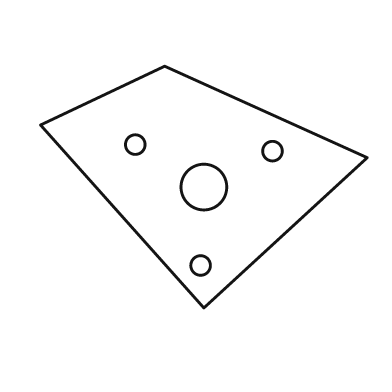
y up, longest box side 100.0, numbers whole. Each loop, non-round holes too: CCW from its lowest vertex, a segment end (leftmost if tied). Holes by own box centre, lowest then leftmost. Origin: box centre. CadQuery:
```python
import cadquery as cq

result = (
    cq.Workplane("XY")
    .moveTo(0.0, -37.0)
    .lineTo(50.0, 9.0)
    .lineTo(-12.0, 37.0)
    .lineTo(-50.0, 19.0)
    .close()
    .moveTo(-1.0, -24.0)
    .circle(3.0)
    .moveTo(0.0, 0.0)
    .circle(7.0)
    .moveTo(21.0, 11.0)
    .circle(3.0)
    .moveTo(-21.0, 13.0)
    .circle(3.0)
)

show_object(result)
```